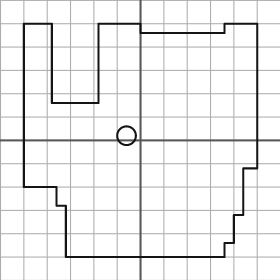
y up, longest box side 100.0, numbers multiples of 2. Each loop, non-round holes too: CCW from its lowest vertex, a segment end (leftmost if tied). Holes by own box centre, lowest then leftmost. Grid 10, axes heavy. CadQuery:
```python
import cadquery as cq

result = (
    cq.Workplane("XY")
    .moveTo(-32.0, -50.0)
    .lineTo(36.0, -50.0)
    .lineTo(36.0, -44.0)
    .lineTo(40.0, -44.0)
    .lineTo(40.0, -32.0)
    .lineTo(44.0, -32.0)
    .lineTo(44.0, -12.0)
    .lineTo(50.0, -12.0)
    .lineTo(50.0, 50.0)
    .lineTo(36.0, 50.0)
    .lineTo(36.0, 46.0)
    .lineTo(0.0, 46.0)
    .lineTo(0.0, 50.0)
    .lineTo(-18.0, 50.0)
    .lineTo(-18.0, 16.0)
    .lineTo(-38.0, 16.0)
    .lineTo(-38.0, 50.0)
    .lineTo(-50.0, 50.0)
    .lineTo(-50.0, -20.0)
    .lineTo(-36.0, -20.0)
    .lineTo(-36.0, -28.0)
    .lineTo(-32.0, -28.0)
    .close()
    .moveTo(-6.0, 2.0)
    .circle(4.0)
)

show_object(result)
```